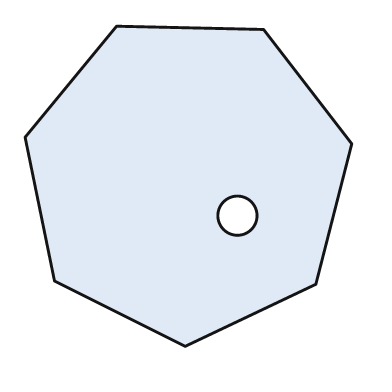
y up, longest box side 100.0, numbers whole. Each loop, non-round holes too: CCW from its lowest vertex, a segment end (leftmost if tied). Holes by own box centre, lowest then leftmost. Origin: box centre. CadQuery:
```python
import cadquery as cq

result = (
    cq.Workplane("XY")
    .moveTo(-1.0, -49.0)
    .lineTo(39.0, -30.0)
    .lineTo(50.0, 13.0)
    .lineTo(23.0, 48.0)
    .lineTo(-22.0, 49.0)
    .lineTo(-50.0, 15.0)
    .lineTo(-41.0, -29.0)
    .close()
    .moveTo(15.0, -9.0)
    .circle(6.0)
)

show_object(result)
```